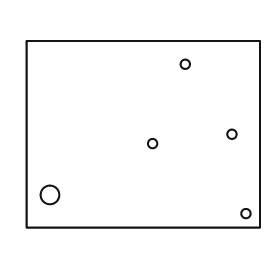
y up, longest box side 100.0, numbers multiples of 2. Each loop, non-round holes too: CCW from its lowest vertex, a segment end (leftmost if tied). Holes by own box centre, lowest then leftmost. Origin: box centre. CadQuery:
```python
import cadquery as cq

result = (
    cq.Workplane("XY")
    .moveTo(-50.0, -40.0)
    .lineTo(50.0, -40.0)
    .lineTo(50.0, 40.0)
    .lineTo(-50.0, 40.0)
    .close()
    .moveTo(44.0, -34.0)
    .circle(2.0)
    .moveTo(-40.0, -26.0)
    .circle(4.0)
    .moveTo(4.0, -4.0)
    .circle(2.0)
    .moveTo(38.0, 0.0)
    .circle(2.0)
    .moveTo(18.0, 30.0)
    .circle(2.0)
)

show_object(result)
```